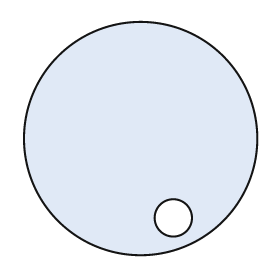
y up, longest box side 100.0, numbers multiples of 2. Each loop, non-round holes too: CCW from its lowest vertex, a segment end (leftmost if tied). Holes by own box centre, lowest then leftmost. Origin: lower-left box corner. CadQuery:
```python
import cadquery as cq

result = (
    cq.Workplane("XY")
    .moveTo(50.0, 50.0)
    .circle(50.0)
    .moveTo(64.0, 16.0)
    .circle(8.0)
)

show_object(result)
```